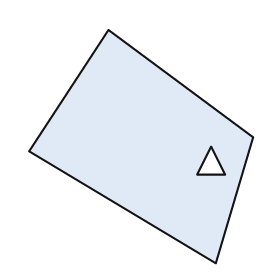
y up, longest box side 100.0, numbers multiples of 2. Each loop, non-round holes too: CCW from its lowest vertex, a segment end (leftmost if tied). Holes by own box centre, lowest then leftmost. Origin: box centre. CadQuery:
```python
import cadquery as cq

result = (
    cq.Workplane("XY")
    .moveTo(32.0, -50.0)
    .lineTo(48.0, 4.0)
    .lineTo(-14.0, 50.0)
    .lineTo(-48.0, -2.0)
    .close()
    .moveTo(24.0, -12.0)
    .lineTo(36.0, -12.0)
    .lineTo(30.0, 0.0)
    .close()
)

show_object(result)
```